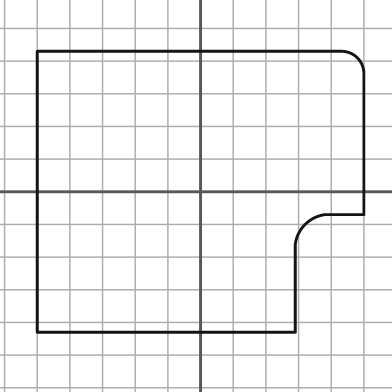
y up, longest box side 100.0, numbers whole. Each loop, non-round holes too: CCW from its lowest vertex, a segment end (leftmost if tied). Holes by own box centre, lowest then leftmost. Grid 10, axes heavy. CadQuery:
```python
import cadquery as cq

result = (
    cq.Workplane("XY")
    .moveTo(-50.0, -43.0)
    .lineTo(29.0, -43.0)
    .lineTo(29.0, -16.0)
    .threePointArc((32.0, -10.0), (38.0, -7.0))
    .lineTo(50.0, -7.0)
    .lineTo(50.0, 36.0)
    .threePointArc((48.0, 41.0), (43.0, 43.0))
    .lineTo(-50.0, 43.0)
    .close()
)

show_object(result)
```